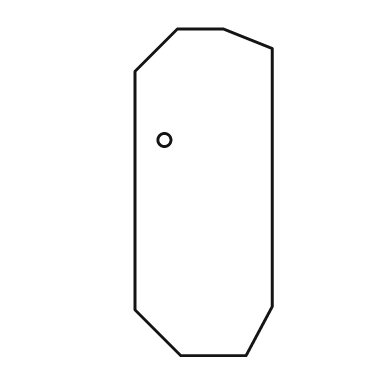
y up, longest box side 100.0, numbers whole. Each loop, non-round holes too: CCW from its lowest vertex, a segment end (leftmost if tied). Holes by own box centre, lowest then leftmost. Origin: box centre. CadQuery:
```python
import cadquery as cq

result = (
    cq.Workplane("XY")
    .moveTo(-7.0, -50.0)
    .lineTo(13.0, -50.0)
    .lineTo(21.0, -35.0)
    .lineTo(21.0, 44.0)
    .lineTo(6.0, 50.0)
    .lineTo(-8.0, 50.0)
    .lineTo(-21.0, 37.0)
    .lineTo(-21.0, -36.0)
    .close()
    .moveTo(-12.0, 16.0)
    .circle(2.0)
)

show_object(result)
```